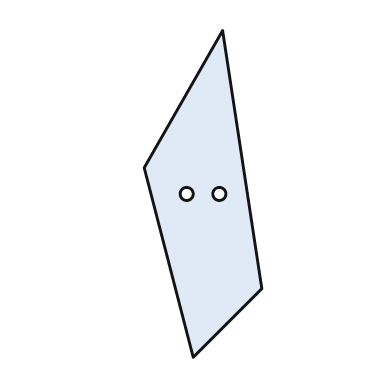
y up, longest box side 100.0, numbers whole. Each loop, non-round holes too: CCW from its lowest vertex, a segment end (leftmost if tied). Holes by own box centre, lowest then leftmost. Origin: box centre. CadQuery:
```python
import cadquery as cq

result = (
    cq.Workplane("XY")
    .moveTo(-3.0, -50.0)
    .lineTo(18.0, -29.0)
    .lineTo(6.0, 50.0)
    .lineTo(-18.0, 8.0)
    .close()
    .moveTo(-5.0, 0.0)
    .circle(2.0)
    .moveTo(5.0, 0.0)
    .circle(2.0)
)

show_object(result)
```